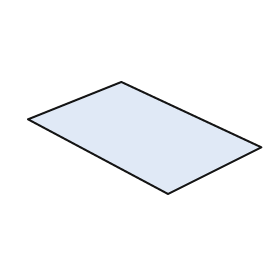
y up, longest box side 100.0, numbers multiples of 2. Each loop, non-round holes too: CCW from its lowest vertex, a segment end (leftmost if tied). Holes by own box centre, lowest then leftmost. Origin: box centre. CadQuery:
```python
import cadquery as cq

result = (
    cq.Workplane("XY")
    .moveTo(10.0, -24.0)
    .lineTo(50.0, -4.0)
    .lineTo(-10.0, 24.0)
    .lineTo(-50.0, 8.0)
    .close()
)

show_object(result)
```